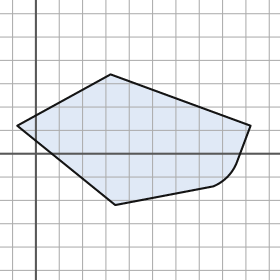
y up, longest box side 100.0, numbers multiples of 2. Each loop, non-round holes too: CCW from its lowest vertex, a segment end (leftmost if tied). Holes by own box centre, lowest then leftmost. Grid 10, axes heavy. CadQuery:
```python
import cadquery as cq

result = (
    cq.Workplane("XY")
    .moveTo(34.0, -22.0)
    .lineTo(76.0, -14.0)
    .threePointArc((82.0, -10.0), (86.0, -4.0))
    .lineTo(92.0, 12.0)
    .lineTo(32.0, 34.0)
    .lineTo(-8.0, 12.0)
    .close()
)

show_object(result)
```